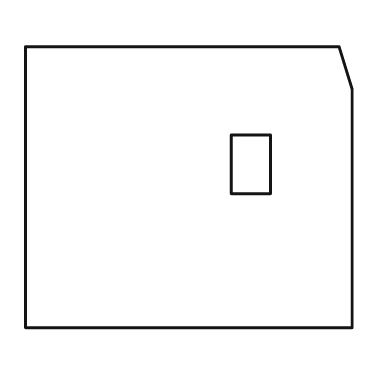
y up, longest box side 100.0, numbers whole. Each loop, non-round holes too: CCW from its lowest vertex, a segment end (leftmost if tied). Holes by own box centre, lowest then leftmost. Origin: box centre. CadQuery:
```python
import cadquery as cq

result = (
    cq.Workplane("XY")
    .moveTo(-50.0, -43.0)
    .lineTo(50.0, -43.0)
    .lineTo(50.0, 30.0)
    .lineTo(46.0, 43.0)
    .lineTo(-50.0, 43.0)
    .close()
    .moveTo(13.0, -2.0)
    .lineTo(25.0, -2.0)
    .lineTo(25.0, 16.0)
    .lineTo(13.0, 16.0)
    .close()
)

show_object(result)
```